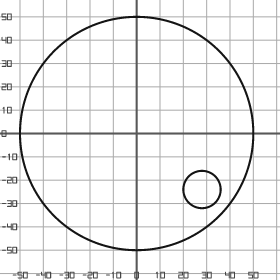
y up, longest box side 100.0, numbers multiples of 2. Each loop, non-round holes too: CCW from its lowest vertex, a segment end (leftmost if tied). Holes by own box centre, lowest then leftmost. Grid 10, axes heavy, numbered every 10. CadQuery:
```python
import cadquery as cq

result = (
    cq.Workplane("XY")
    .moveTo(0.0, 0.0)
    .circle(50.0)
    .moveTo(28.0, -24.0)
    .circle(8.0)
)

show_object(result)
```